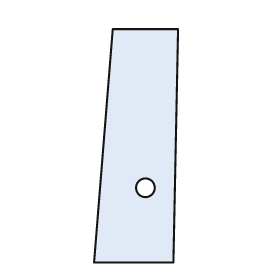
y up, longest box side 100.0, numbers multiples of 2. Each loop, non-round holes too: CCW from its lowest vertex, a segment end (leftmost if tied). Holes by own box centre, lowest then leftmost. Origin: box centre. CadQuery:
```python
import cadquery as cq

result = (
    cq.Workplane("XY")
    .moveTo(-18.0, -50.0)
    .lineTo(16.0, -50.0)
    .lineTo(18.0, 50.0)
    .lineTo(-10.0, 50.0)
    .close()
    .moveTo(4.0, -18.0)
    .circle(4.0)
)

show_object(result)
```